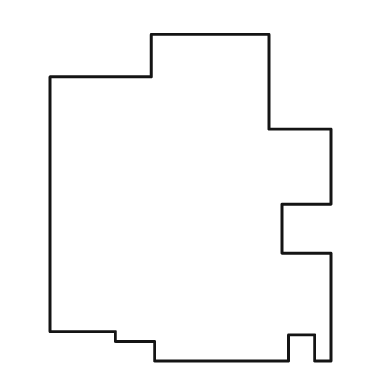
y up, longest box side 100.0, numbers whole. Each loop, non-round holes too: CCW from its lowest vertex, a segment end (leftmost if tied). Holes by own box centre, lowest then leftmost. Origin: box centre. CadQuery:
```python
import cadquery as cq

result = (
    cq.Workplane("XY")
    .moveTo(-11.0, -50.0)
    .lineTo(30.0, -50.0)
    .lineTo(30.0, -42.0)
    .lineTo(38.0, -42.0)
    .lineTo(38.0, -50.0)
    .lineTo(43.0, -50.0)
    .lineTo(43.0, -17.0)
    .lineTo(28.0, -17.0)
    .lineTo(28.0, -2.0)
    .lineTo(43.0, -2.0)
    .lineTo(43.0, 21.0)
    .lineTo(24.0, 21.0)
    .lineTo(24.0, 50.0)
    .lineTo(-12.0, 50.0)
    .lineTo(-12.0, 37.0)
    .lineTo(-43.0, 37.0)
    .lineTo(-43.0, -41.0)
    .lineTo(-23.0, -41.0)
    .lineTo(-23.0, -44.0)
    .lineTo(-11.0, -44.0)
    .close()
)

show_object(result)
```